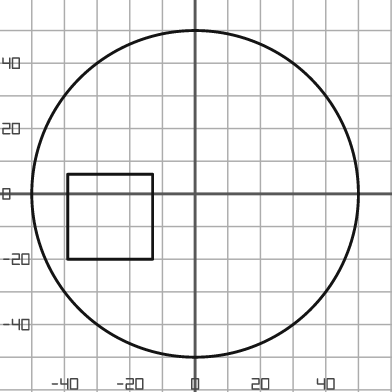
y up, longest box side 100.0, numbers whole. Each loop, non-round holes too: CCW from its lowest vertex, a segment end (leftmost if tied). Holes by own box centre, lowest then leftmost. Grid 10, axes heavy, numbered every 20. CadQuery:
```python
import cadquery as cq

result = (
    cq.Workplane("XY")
    .moveTo(0.0, 0.0)
    .circle(50.0)
    .moveTo(-39.0, -20.0)
    .lineTo(-13.0, -20.0)
    .lineTo(-13.0, 6.0)
    .lineTo(-39.0, 6.0)
    .close()
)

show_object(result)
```